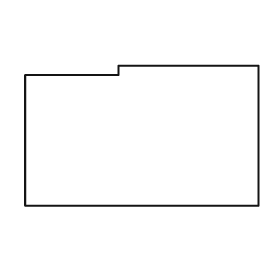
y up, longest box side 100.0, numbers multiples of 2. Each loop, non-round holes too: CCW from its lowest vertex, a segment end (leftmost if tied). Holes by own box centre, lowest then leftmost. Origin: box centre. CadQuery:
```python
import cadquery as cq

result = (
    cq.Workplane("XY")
    .moveTo(-50.0, -30.0)
    .lineTo(50.0, -30.0)
    .lineTo(50.0, 30.0)
    .lineTo(-10.0, 30.0)
    .lineTo(-10.0, 26.0)
    .lineTo(-50.0, 26.0)
    .close()
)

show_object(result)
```